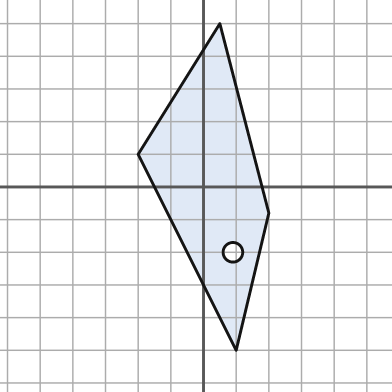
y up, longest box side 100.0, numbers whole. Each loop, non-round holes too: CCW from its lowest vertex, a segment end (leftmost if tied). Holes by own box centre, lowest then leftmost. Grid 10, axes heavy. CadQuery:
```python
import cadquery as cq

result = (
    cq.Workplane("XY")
    .moveTo(10.0, -50.0)
    .lineTo(20.0, -8.0)
    .lineTo(5.0, 50.0)
    .lineTo(-20.0, 10.0)
    .close()
    .moveTo(9.0, -20.0)
    .circle(3.0)
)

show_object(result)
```